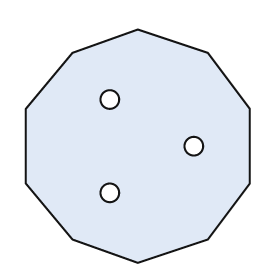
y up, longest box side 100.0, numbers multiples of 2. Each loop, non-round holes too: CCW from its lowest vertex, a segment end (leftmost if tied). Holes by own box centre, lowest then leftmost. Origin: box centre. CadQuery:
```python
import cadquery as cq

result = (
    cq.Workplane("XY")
    .moveTo(0.0, -50.0)
    .lineTo(30.0, -40.0)
    .lineTo(48.0, -16.0)
    .lineTo(48.0, 16.0)
    .lineTo(30.0, 40.0)
    .lineTo(0.0, 50.0)
    .lineTo(-28.0, 40.0)
    .lineTo(-48.0, 16.0)
    .lineTo(-48.0, -16.0)
    .lineTo(-28.0, -40.0)
    .close()
    .moveTo(-12.0, -20.0)
    .circle(4.0)
    .moveTo(24.0, 0.0)
    .circle(4.0)
    .moveTo(-12.0, 20.0)
    .circle(4.0)
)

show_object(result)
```